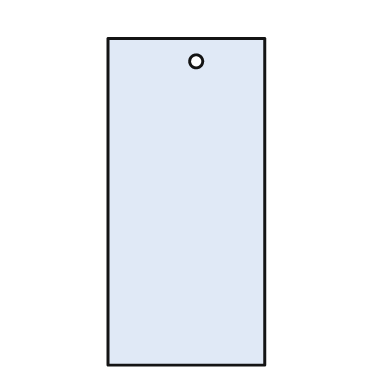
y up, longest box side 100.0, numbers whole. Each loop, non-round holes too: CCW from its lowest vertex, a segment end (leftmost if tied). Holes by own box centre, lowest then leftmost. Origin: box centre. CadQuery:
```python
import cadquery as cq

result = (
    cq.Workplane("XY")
    .moveTo(-24.0, -50.0)
    .lineTo(24.0, -50.0)
    .lineTo(24.0, 50.0)
    .lineTo(-24.0, 50.0)
    .close()
    .moveTo(3.0, 43.0)
    .circle(2.0)
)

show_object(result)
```